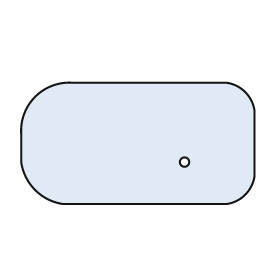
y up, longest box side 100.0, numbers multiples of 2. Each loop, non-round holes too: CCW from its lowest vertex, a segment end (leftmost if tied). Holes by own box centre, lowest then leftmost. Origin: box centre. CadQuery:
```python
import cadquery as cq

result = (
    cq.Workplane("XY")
    .moveTo(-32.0, -26.0)
    .lineTo(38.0, -26.0)
    .threePointArc((46.0, -22.0), (50.0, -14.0))
    .lineTo(50.0, 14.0)
    .threePointArc((46.0, 22.0), (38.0, 26.0))
    .lineTo(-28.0, 26.0)
    .threePointArc((-44.0, 20.0), (-50.0, 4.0))
    .lineTo(-50.0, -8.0)
    .threePointArc((-44.0, -20.0), (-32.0, -26.0))
    .close()
    .moveTo(20.0, -8.0)
    .circle(2.0)
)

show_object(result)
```